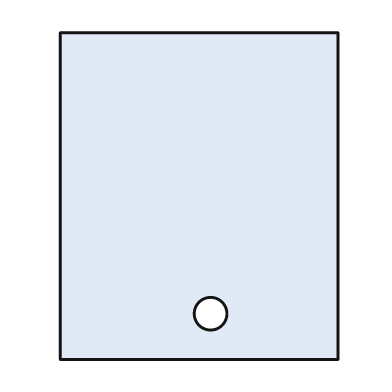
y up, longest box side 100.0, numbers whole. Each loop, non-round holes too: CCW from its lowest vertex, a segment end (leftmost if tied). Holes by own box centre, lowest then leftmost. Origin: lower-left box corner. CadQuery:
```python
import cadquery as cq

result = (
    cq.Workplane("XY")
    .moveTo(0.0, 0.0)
    .lineTo(85.0, 0.0)
    .lineTo(85.0, 100.0)
    .lineTo(0.0, 100.0)
    .close()
    .moveTo(46.0, 14.0)
    .circle(5.0)
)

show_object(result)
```